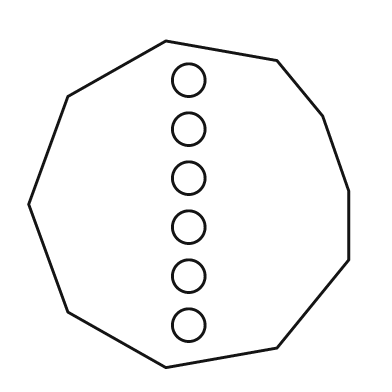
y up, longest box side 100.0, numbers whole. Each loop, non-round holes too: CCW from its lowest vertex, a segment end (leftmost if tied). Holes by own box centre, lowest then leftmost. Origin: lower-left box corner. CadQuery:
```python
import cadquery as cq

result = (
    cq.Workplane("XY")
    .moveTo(42.0, 0.0)
    .lineTo(76.0, 6.0)
    .lineTo(98.0, 33.0)
    .lineTo(98.0, 54.0)
    .lineTo(90.0, 77.0)
    .lineTo(76.0, 94.0)
    .lineTo(42.0, 100.0)
    .lineTo(12.0, 83.0)
    .lineTo(0.0, 50.0)
    .lineTo(12.0, 17.0)
    .close()
    .moveTo(49.0, 13.0)
    .circle(5.0)
    .moveTo(49.0, 28.0)
    .circle(5.0)
    .moveTo(49.0, 43.0)
    .circle(5.0)
    .moveTo(49.0, 58.0)
    .circle(5.0)
    .moveTo(49.0, 73.0)
    .circle(5.0)
    .moveTo(49.0, 88.0)
    .circle(5.0)
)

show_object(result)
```